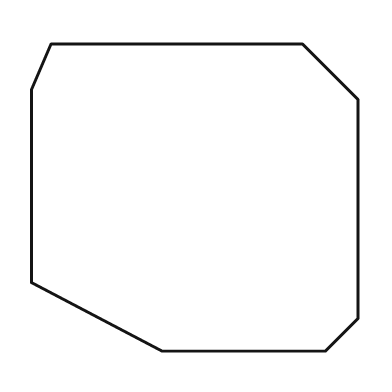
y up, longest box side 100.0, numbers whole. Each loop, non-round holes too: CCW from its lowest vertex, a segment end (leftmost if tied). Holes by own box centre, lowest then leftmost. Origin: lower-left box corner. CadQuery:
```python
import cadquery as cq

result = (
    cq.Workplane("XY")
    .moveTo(40.0, 0.0)
    .lineTo(90.0, 0.0)
    .lineTo(100.0, 10.0)
    .lineTo(100.0, 77.0)
    .lineTo(83.0, 94.0)
    .lineTo(6.0, 94.0)
    .lineTo(0.0, 80.0)
    .lineTo(0.0, 21.0)
    .close()
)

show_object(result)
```